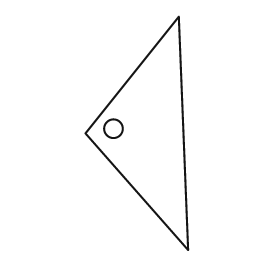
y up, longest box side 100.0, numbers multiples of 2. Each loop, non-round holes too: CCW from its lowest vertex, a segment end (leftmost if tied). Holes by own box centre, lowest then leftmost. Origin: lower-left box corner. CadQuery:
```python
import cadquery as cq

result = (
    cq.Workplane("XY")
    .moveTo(44.0, 0.0)
    .lineTo(40.0, 100.0)
    .lineTo(0.0, 50.0)
    .close()
    .moveTo(12.0, 52.0)
    .circle(4.0)
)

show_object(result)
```